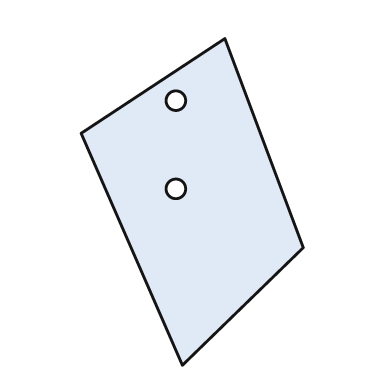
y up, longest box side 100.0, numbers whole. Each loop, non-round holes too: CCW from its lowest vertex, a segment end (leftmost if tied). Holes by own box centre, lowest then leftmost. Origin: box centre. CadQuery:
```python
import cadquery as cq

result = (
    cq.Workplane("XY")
    .moveTo(-3.0, -50.0)
    .lineTo(34.0, -14.0)
    .lineTo(10.0, 50.0)
    .lineTo(-34.0, 21.0)
    .close()
    .moveTo(-5.0, 4.0)
    .circle(3.0)
    .moveTo(-5.0, 31.0)
    .circle(3.0)
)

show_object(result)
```